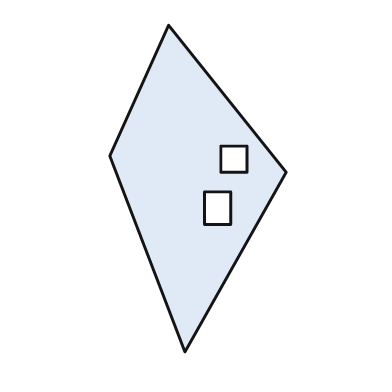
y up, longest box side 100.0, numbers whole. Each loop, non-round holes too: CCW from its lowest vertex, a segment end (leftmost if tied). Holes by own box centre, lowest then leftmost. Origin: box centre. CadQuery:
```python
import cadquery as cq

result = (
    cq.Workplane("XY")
    .moveTo(-4.0, -50.0)
    .lineTo(27.0, 5.0)
    .lineTo(-9.0, 50.0)
    .lineTo(-27.0, 10.0)
    .close()
    .moveTo(2.0, -11.0)
    .lineTo(10.0, -11.0)
    .lineTo(10.0, -1.0)
    .lineTo(2.0, -1.0)
    .close()
    .moveTo(7.0, 5.0)
    .lineTo(15.0, 5.0)
    .lineTo(15.0, 13.0)
    .lineTo(7.0, 13.0)
    .close()
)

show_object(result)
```